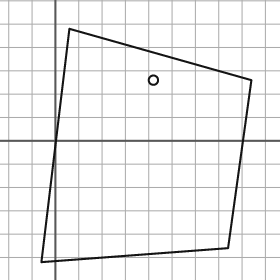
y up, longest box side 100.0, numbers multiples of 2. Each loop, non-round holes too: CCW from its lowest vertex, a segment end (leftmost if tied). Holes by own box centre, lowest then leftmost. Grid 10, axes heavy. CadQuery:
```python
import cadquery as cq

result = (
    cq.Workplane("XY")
    .moveTo(-6.0, -52.0)
    .lineTo(74.0, -46.0)
    .lineTo(84.0, 26.0)
    .lineTo(6.0, 48.0)
    .close()
    .moveTo(42.0, 26.0)
    .circle(2.0)
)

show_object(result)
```